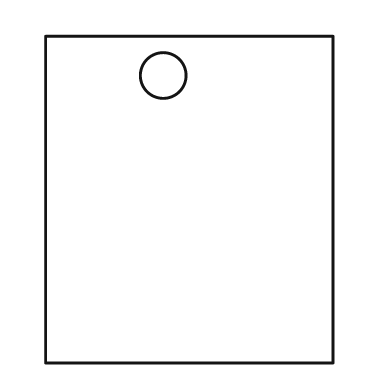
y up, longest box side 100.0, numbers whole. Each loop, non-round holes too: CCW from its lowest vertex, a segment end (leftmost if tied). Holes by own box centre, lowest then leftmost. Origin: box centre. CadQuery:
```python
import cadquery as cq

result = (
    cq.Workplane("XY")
    .moveTo(-44.0, -50.0)
    .lineTo(44.0, -50.0)
    .lineTo(44.0, 50.0)
    .lineTo(-44.0, 50.0)
    .close()
    .moveTo(-8.0, 38.0)
    .circle(7.0)
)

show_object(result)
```